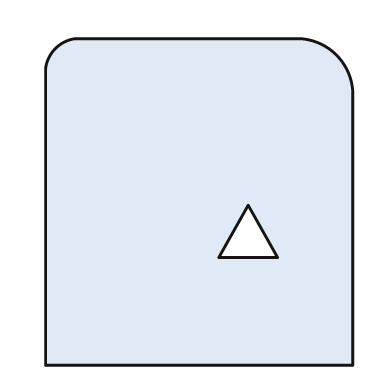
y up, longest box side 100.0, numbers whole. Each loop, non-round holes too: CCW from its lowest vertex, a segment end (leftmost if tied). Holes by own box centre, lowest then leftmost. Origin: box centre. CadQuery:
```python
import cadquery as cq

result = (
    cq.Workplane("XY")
    .moveTo(-47.0, -50.0)
    .lineTo(47.0, -50.0)
    .lineTo(47.0, 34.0)
    .threePointArc((42.0, 45.0), (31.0, 50.0))
    .lineTo(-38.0, 50.0)
    .threePointArc((-44.0, 47.0), (-47.0, 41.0))
    .close()
    .moveTo(6.0, -17.0)
    .lineTo(24.0, -17.0)
    .lineTo(15.0, -1.0)
    .close()
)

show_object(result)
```